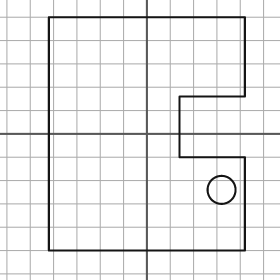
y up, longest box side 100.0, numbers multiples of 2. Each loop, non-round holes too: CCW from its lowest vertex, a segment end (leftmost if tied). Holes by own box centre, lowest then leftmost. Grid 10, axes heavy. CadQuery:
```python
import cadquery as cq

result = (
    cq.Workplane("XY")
    .moveTo(-42.0, -50.0)
    .lineTo(42.0, -50.0)
    .lineTo(42.0, -10.0)
    .lineTo(14.0, -10.0)
    .lineTo(14.0, 16.0)
    .lineTo(42.0, 16.0)
    .lineTo(42.0, 50.0)
    .lineTo(-42.0, 50.0)
    .close()
    .moveTo(32.0, -24.0)
    .circle(6.0)
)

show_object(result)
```